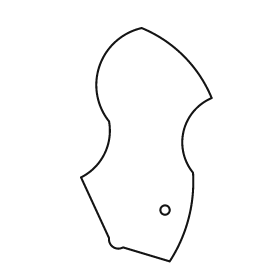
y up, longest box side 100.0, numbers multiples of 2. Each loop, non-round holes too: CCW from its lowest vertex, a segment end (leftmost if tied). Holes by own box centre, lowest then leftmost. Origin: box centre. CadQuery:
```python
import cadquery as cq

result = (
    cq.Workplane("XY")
    .moveTo(10.0, -50.0)
    .threePointArc((18.0, -32.0), (20.0, -12.0))
    .threePointArc((16.0, 6.0), (28.0, 20.0))
    .threePointArc((16.0, 38.0), (-2.0, 50.0))
    .threePointArc((-20.0, 34.0), (-16.0, 10.0))
    .threePointArc((-18.0, -4.0), (-28.0, -14.0))
    .lineTo(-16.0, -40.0)
    .threePointArc((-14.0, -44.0), (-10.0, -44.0))
    .close()
    .moveTo(8.0, -28.0)
    .circle(2.0)
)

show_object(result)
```